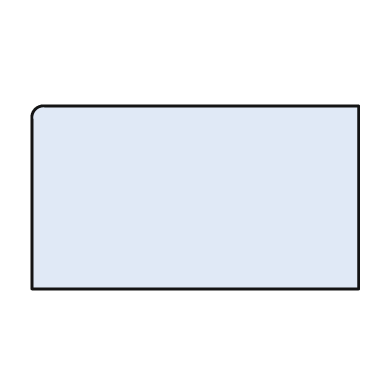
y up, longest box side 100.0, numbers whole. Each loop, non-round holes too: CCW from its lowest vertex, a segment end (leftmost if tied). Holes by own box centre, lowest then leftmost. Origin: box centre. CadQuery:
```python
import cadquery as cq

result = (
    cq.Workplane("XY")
    .moveTo(-50.0, -28.0)
    .lineTo(50.0, -28.0)
    .lineTo(50.0, 28.0)
    .lineTo(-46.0, 28.0)
    .threePointArc((-49.0, 27.0), (-50.0, 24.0))
    .close()
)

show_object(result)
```